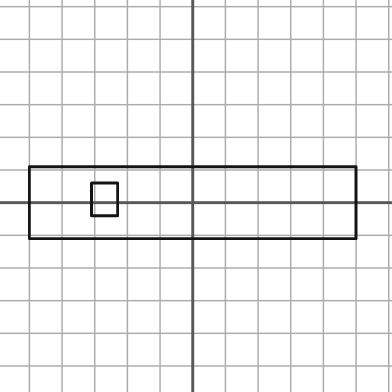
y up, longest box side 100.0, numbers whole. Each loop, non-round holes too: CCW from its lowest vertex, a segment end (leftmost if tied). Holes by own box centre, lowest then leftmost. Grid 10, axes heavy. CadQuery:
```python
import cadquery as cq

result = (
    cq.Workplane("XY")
    .moveTo(-50.0, -11.0)
    .lineTo(50.0, -11.0)
    .lineTo(50.0, 11.0)
    .lineTo(-50.0, 11.0)
    .close()
    .moveTo(-31.0, -4.0)
    .lineTo(-23.0, -4.0)
    .lineTo(-23.0, 6.0)
    .lineTo(-31.0, 6.0)
    .close()
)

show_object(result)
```